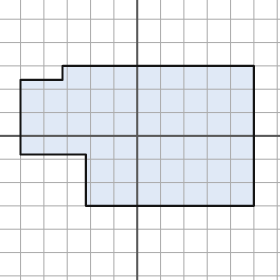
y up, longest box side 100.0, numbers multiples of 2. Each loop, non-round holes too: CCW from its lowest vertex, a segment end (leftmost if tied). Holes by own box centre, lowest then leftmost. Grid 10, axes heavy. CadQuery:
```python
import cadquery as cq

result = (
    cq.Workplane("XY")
    .moveTo(-22.0, -30.0)
    .lineTo(50.0, -30.0)
    .lineTo(50.0, 30.0)
    .lineTo(-32.0, 30.0)
    .lineTo(-32.0, 24.0)
    .lineTo(-50.0, 24.0)
    .lineTo(-50.0, -8.0)
    .lineTo(-22.0, -8.0)
    .close()
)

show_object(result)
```